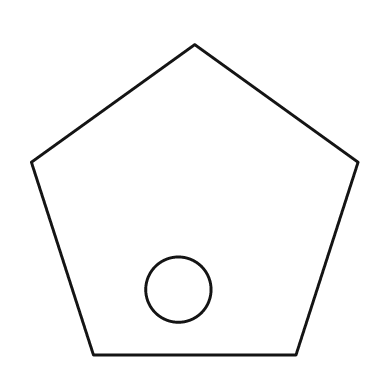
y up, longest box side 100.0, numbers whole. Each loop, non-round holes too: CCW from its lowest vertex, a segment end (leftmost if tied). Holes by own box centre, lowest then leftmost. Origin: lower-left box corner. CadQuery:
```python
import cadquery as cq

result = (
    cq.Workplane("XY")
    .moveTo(19.0, 0.0)
    .lineTo(81.0, 0.0)
    .lineTo(100.0, 59.0)
    .lineTo(50.0, 95.0)
    .lineTo(0.0, 59.0)
    .close()
    .moveTo(45.0, 20.0)
    .circle(10.0)
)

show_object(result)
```